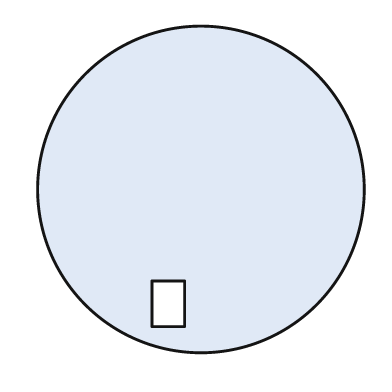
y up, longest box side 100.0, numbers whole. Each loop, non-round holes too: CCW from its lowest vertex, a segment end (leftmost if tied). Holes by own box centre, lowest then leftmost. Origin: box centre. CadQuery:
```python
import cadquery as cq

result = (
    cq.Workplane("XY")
    .moveTo(0.0, 0.0)
    .circle(50.0)
    .moveTo(-15.0, -42.0)
    .lineTo(-5.0, -42.0)
    .lineTo(-5.0, -28.0)
    .lineTo(-15.0, -28.0)
    .close()
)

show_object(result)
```